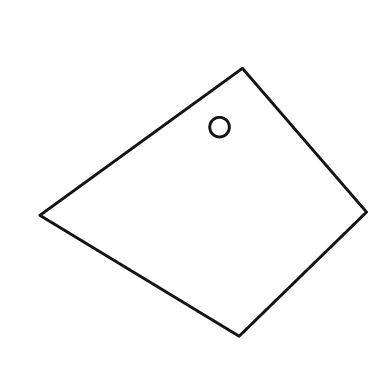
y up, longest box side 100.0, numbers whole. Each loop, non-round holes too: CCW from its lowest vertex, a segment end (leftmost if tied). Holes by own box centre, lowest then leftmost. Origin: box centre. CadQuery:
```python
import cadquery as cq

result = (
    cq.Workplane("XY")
    .moveTo(11.0, -41.0)
    .lineTo(50.0, -3.0)
    .lineTo(12.0, 41.0)
    .lineTo(-50.0, -4.0)
    .close()
    .moveTo(5.0, 23.0)
    .circle(3.0)
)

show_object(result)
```